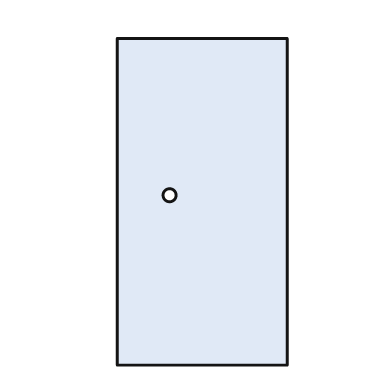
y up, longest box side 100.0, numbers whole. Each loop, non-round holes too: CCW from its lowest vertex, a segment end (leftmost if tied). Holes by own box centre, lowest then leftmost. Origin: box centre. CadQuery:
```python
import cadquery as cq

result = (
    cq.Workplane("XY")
    .moveTo(-26.0, -50.0)
    .lineTo(26.0, -50.0)
    .lineTo(26.0, 50.0)
    .lineTo(-26.0, 50.0)
    .close()
    .moveTo(-10.0, 2.0)
    .circle(2.0)
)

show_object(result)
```